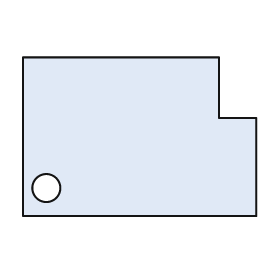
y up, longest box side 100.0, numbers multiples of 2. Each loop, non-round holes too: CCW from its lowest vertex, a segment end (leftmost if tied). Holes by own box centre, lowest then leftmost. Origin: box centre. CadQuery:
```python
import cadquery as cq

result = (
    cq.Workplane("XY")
    .moveTo(-50.0, -34.0)
    .lineTo(50.0, -34.0)
    .lineTo(50.0, 8.0)
    .lineTo(34.0, 8.0)
    .lineTo(34.0, 34.0)
    .lineTo(-50.0, 34.0)
    .close()
    .moveTo(-40.0, -22.0)
    .circle(6.0)
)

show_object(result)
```